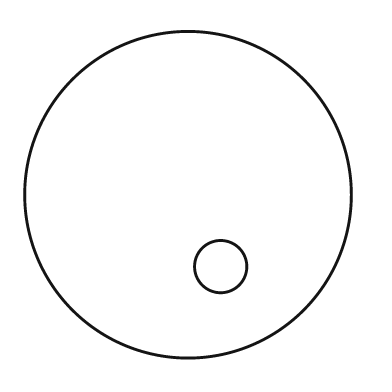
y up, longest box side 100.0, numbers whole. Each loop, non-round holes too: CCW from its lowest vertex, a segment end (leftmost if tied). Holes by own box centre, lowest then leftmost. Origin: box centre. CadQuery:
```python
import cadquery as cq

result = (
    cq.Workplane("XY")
    .moveTo(0.0, 0.0)
    .circle(50.0)
    .moveTo(10.0, -22.0)
    .circle(8.0)
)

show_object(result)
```